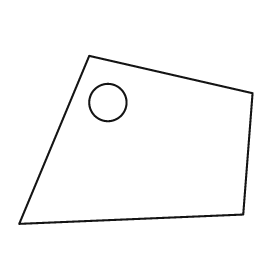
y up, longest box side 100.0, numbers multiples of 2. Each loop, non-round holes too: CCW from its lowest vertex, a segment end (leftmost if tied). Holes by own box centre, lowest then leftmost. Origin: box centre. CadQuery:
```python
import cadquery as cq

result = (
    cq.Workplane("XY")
    .moveTo(-50.0, -36.0)
    .lineTo(46.0, -32.0)
    .lineTo(50.0, 20.0)
    .lineTo(-20.0, 36.0)
    .close()
    .moveTo(-12.0, 16.0)
    .circle(8.0)
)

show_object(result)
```